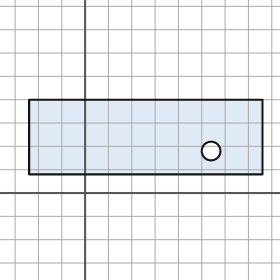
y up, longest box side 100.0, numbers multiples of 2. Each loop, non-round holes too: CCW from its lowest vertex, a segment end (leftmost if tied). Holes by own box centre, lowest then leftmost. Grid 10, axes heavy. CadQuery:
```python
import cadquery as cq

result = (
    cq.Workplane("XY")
    .moveTo(-24.0, 8.0)
    .lineTo(76.0, 8.0)
    .lineTo(76.0, 40.0)
    .lineTo(-24.0, 40.0)
    .close()
    .moveTo(54.0, 18.0)
    .circle(4.0)
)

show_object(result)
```